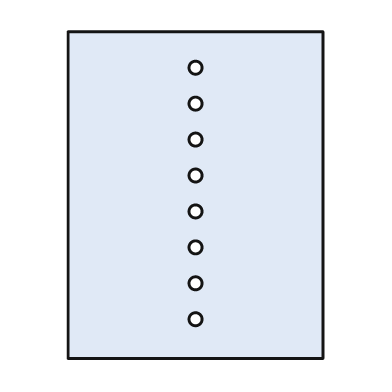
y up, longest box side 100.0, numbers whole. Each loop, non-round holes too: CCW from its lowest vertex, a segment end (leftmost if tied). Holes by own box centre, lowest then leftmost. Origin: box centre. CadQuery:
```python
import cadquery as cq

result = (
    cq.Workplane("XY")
    .moveTo(-39.0, -50.0)
    .lineTo(39.0, -50.0)
    .lineTo(39.0, 50.0)
    .lineTo(-39.0, 50.0)
    .close()
    .moveTo(0.0, -38.0)
    .circle(2.0)
    .moveTo(0.0, -27.0)
    .circle(2.0)
    .moveTo(0.0, -16.0)
    .circle(2.0)
    .moveTo(0.0, -5.0)
    .circle(2.0)
    .moveTo(0.0, 6.0)
    .circle(2.0)
    .moveTo(0.0, 17.0)
    .circle(2.0)
    .moveTo(0.0, 28.0)
    .circle(2.0)
    .moveTo(0.0, 39.0)
    .circle(2.0)
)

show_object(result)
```